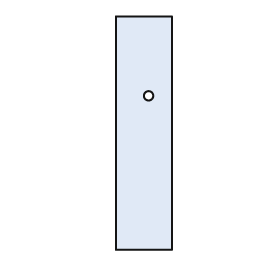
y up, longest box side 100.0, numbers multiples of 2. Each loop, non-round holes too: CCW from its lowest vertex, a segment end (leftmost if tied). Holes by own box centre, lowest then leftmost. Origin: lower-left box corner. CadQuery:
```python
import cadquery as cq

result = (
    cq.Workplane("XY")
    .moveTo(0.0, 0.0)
    .lineTo(24.0, 0.0)
    .lineTo(24.0, 100.0)
    .lineTo(0.0, 100.0)
    .close()
    .moveTo(14.0, 66.0)
    .circle(2.0)
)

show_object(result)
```